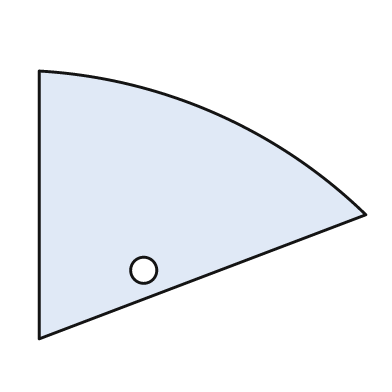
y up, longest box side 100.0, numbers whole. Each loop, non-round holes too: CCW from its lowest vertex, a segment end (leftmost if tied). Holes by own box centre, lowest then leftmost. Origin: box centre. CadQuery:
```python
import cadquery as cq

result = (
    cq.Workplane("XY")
    .moveTo(-50.0, -41.0)
    .lineTo(50.0, -3.0)
    .threePointArc((4.0, 28.0), (-50.0, 41.0))
    .close()
    .moveTo(-18.0, -20.0)
    .circle(4.0)
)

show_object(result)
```